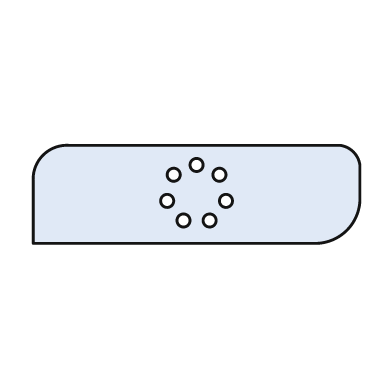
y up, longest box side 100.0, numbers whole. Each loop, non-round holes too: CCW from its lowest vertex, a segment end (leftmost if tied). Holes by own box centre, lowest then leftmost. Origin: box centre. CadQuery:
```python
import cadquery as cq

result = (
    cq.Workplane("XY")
    .moveTo(-50.0, -15.0)
    .lineTo(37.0, -15.0)
    .threePointArc((46.0, -11.0), (50.0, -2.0))
    .lineTo(50.0, 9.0)
    .threePointArc((48.0, 13.0), (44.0, 15.0))
    .lineTo(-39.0, 15.0)
    .threePointArc((-47.0, 12.0), (-50.0, 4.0))
    .close()
    .moveTo(-4.0, -8.0)
    .circle(2.0)
    .moveTo(4.0, -8.0)
    .circle(2.0)
    .moveTo(-9.0, -2.0)
    .circle(2.0)
    .moveTo(9.0, -2.0)
    .circle(2.0)
    .moveTo(-7.0, 6.0)
    .circle(2.0)
    .moveTo(7.0, 6.0)
    .circle(2.0)
    .moveTo(0.0, 9.0)
    .circle(2.0)
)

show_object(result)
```